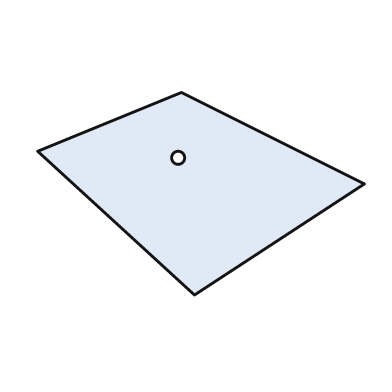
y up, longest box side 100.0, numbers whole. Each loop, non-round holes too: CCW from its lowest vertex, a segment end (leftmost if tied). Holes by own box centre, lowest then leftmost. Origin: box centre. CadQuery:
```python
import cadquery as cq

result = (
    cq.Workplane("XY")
    .moveTo(-2.0, -31.0)
    .lineTo(50.0, 3.0)
    .lineTo(-6.0, 31.0)
    .lineTo(-50.0, 13.0)
    .close()
    .moveTo(-7.0, 11.0)
    .circle(2.0)
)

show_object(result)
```